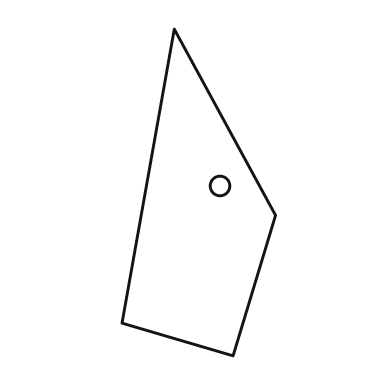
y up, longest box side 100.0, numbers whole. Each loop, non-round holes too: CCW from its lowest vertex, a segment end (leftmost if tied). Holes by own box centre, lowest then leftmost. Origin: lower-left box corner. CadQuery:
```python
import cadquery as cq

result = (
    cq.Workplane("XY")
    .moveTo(34.0, 0.0)
    .lineTo(47.0, 43.0)
    .lineTo(16.0, 100.0)
    .lineTo(0.0, 10.0)
    .close()
    .moveTo(30.0, 52.0)
    .circle(3.0)
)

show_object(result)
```